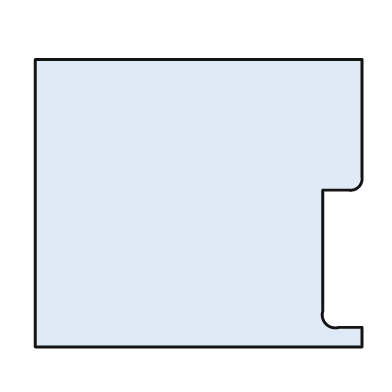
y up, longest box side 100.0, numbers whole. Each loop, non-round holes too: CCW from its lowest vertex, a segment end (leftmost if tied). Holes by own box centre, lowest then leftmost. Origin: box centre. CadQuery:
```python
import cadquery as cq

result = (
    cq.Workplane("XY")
    .moveTo(-50.0, -44.0)
    .lineTo(50.0, -44.0)
    .lineTo(50.0, -38.0)
    .lineTo(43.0, -38.0)
    .threePointArc((39.0, -37.0), (38.0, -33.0))
    .lineTo(38.0, 4.0)
    .lineTo(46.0, 4.0)
    .threePointArc((49.0, 5.0), (50.0, 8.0))
    .lineTo(50.0, 44.0)
    .lineTo(-50.0, 44.0)
    .close()
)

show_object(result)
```